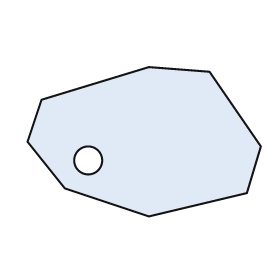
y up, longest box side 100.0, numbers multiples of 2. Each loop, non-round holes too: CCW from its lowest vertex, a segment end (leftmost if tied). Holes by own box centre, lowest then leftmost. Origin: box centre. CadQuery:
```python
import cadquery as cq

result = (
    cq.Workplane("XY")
    .moveTo(2.0, -32.0)
    .lineTo(44.0, -22.0)
    .lineTo(50.0, -2.0)
    .lineTo(28.0, 30.0)
    .lineTo(2.0, 32.0)
    .lineTo(-44.0, 18.0)
    .lineTo(-50.0, 0.0)
    .lineTo(-34.0, -20.0)
    .close()
    .moveTo(-24.0, -8.0)
    .circle(6.0)
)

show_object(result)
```